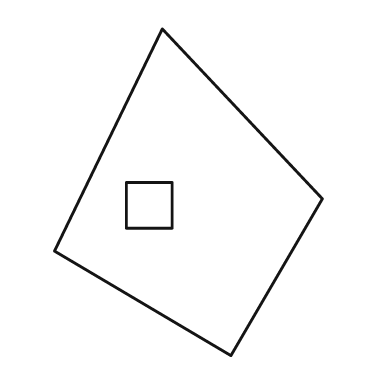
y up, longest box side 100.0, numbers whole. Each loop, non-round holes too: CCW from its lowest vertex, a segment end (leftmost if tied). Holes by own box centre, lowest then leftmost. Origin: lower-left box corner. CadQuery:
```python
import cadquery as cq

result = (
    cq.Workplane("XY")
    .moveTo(54.0, 0.0)
    .lineTo(82.0, 48.0)
    .lineTo(33.0, 100.0)
    .lineTo(0.0, 32.0)
    .close()
    .moveTo(22.0, 39.0)
    .lineTo(36.0, 39.0)
    .lineTo(36.0, 53.0)
    .lineTo(22.0, 53.0)
    .close()
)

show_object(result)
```